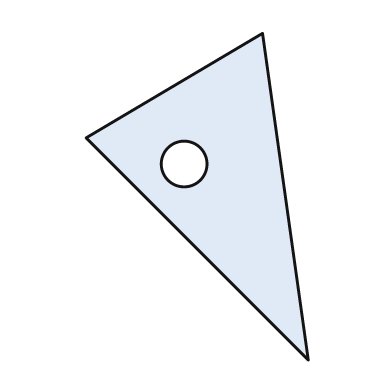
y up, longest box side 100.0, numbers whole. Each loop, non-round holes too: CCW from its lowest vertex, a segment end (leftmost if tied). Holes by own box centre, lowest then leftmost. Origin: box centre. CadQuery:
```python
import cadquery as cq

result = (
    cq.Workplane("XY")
    .moveTo(34.0, -50.0)
    .lineTo(20.0, 50.0)
    .lineTo(-34.0, 18.0)
    .close()
    .moveTo(-4.0, 10.0)
    .circle(7.0)
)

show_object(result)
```